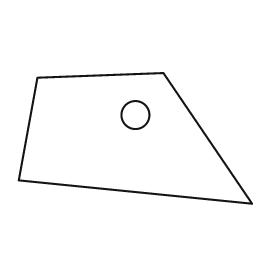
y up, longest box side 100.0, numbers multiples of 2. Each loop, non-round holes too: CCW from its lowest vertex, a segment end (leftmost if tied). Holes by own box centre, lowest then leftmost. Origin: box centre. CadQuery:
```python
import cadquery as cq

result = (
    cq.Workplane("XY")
    .moveTo(50.0, -28.0)
    .lineTo(12.0, 28.0)
    .lineTo(-42.0, 26.0)
    .lineTo(-50.0, -18.0)
    .close()
    .moveTo(0.0, 10.0)
    .circle(6.0)
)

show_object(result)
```